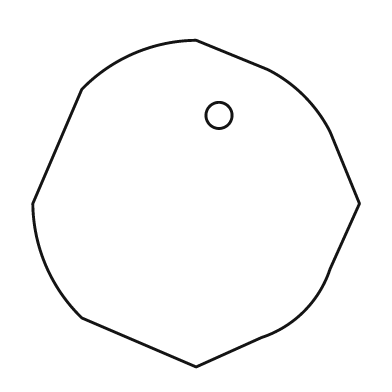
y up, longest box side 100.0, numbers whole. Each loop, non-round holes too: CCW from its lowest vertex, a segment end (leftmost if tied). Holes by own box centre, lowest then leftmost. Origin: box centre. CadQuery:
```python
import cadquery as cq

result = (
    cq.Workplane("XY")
    .moveTo(0.0, -50.0)
    .lineTo(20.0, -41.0)
    .threePointArc((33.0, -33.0), (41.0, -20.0))
    .lineTo(50.0, 0.0)
    .lineTo(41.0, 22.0)
    .threePointArc((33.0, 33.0), (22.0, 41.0))
    .lineTo(0.0, 50.0)
    .threePointArc((-19.0, 46.0), (-35.0, 35.0))
    .lineTo(-50.0, 0.0)
    .threePointArc((-46.0, -19.0), (-35.0, -35.0))
    .close()
    .moveTo(7.0, 27.0)
    .circle(4.0)
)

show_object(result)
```